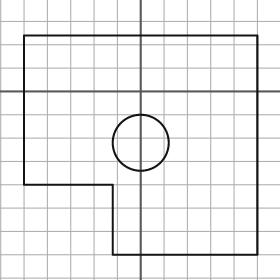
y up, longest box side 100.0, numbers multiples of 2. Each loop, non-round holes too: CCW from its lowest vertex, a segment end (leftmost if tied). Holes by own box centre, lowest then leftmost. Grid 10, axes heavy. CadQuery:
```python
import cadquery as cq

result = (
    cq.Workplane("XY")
    .moveTo(-12.0, -70.0)
    .lineTo(50.0, -70.0)
    .lineTo(50.0, 24.0)
    .lineTo(-50.0, 24.0)
    .lineTo(-50.0, -40.0)
    .lineTo(-12.0, -40.0)
    .close()
    .moveTo(0.0, -22.0)
    .circle(12.0)
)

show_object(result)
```